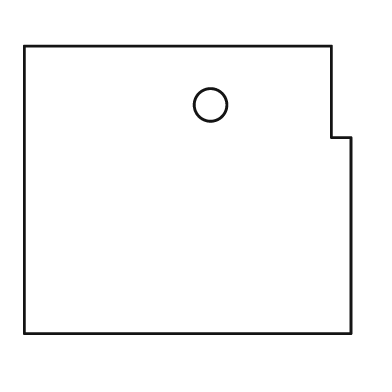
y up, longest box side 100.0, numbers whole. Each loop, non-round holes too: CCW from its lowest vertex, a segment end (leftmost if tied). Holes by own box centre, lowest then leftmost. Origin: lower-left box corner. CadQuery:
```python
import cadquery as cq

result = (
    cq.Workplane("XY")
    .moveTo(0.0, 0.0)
    .lineTo(100.0, 0.0)
    .lineTo(100.0, 60.0)
    .lineTo(94.0, 60.0)
    .lineTo(94.0, 88.0)
    .lineTo(0.0, 88.0)
    .close()
    .moveTo(57.0, 70.0)
    .circle(5.0)
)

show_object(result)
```